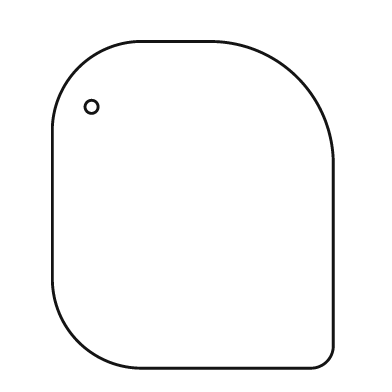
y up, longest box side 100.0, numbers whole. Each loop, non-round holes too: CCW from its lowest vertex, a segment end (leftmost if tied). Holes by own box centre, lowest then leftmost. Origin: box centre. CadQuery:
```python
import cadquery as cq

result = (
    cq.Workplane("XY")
    .moveTo(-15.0, -50.0)
    .lineTo(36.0, -50.0)
    .threePointArc((41.0, -48.0), (43.0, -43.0))
    .lineTo(43.0, 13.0)
    .threePointArc((32.0, 39.0), (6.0, 50.0))
    .lineTo(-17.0, 50.0)
    .threePointArc((-35.0, 42.0), (-43.0, 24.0))
    .lineTo(-43.0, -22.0)
    .threePointArc((-35.0, -42.0), (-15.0, -50.0))
    .close()
    .moveTo(-31.0, 30.0)
    .circle(2.0)
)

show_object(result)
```